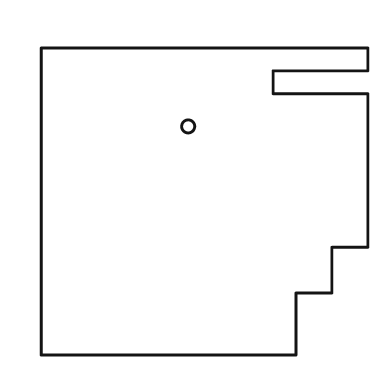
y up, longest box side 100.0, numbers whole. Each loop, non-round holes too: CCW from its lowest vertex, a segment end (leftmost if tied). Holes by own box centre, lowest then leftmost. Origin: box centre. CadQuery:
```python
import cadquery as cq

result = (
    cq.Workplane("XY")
    .moveTo(-50.0, -47.0)
    .lineTo(28.0, -47.0)
    .lineTo(28.0, -28.0)
    .lineTo(39.0, -28.0)
    .lineTo(39.0, -14.0)
    .lineTo(50.0, -14.0)
    .lineTo(50.0, 33.0)
    .lineTo(21.0, 33.0)
    .lineTo(21.0, 40.0)
    .lineTo(50.0, 40.0)
    .lineTo(50.0, 47.0)
    .lineTo(-50.0, 47.0)
    .close()
    .moveTo(-5.0, 23.0)
    .circle(2.0)
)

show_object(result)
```